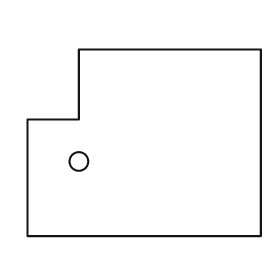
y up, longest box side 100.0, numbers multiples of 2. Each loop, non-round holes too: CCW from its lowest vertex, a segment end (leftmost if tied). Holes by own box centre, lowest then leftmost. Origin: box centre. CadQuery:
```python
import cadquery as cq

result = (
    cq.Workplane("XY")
    .moveTo(-50.0, -40.0)
    .lineTo(50.0, -40.0)
    .lineTo(50.0, 40.0)
    .lineTo(-28.0, 40.0)
    .lineTo(-28.0, 10.0)
    .lineTo(-50.0, 10.0)
    .close()
    .moveTo(-28.0, -8.0)
    .circle(4.0)
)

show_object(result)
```